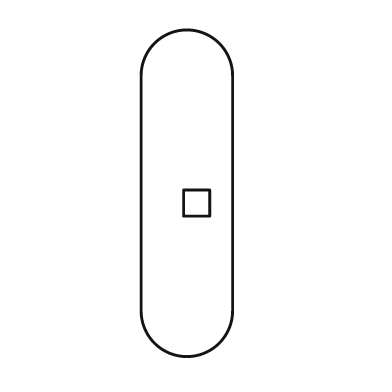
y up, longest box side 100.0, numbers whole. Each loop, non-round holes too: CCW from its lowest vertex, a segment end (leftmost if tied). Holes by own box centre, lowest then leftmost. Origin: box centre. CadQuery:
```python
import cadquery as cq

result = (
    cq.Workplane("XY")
    .moveTo(-14.0, -36.0)
    .threePointArc((0.0, -50.0), (14.0, -36.0))
    .lineTo(14.0, 36.0)
    .threePointArc((0.0, 50.0), (-14.0, 36.0))
    .close()
    .moveTo(-1.0, -7.0)
    .lineTo(7.0, -7.0)
    .lineTo(7.0, 1.0)
    .lineTo(-1.0, 1.0)
    .close()
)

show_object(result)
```